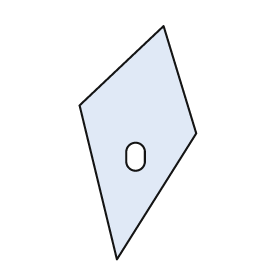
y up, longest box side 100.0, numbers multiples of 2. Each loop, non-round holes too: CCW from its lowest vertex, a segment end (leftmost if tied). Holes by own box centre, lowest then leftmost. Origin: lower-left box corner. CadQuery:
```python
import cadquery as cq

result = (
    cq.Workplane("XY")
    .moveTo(16.0, 0.0)
    .lineTo(50.0, 54.0)
    .lineTo(36.0, 100.0)
    .lineTo(0.0, 66.0)
    .close()
    .moveTo(20.0, 42.0)
    .threePointArc((24.0, 38.0), (28.0, 42.0))
    .lineTo(28.0, 46.0)
    .threePointArc((24.0, 50.0), (20.0, 46.0))
    .close()
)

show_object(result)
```